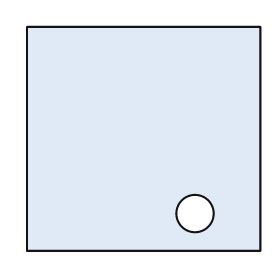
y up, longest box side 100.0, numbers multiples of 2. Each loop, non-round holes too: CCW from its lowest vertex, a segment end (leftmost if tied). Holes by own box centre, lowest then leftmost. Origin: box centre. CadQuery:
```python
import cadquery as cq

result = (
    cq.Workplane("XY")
    .moveTo(-50.0, -48.0)
    .lineTo(50.0, -48.0)
    .lineTo(50.0, 48.0)
    .lineTo(-50.0, 48.0)
    .close()
    .moveTo(22.0, -32.0)
    .circle(8.0)
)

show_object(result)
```